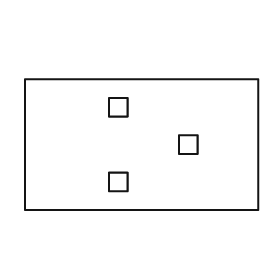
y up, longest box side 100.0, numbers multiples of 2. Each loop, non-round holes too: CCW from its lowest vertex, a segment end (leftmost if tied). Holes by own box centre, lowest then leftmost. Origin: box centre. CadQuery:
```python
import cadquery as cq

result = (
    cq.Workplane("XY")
    .moveTo(-50.0, -28.0)
    .lineTo(50.0, -28.0)
    .lineTo(50.0, 28.0)
    .lineTo(-50.0, 28.0)
    .close()
    .moveTo(-14.0, -20.0)
    .lineTo(-6.0, -20.0)
    .lineTo(-6.0, -12.0)
    .lineTo(-14.0, -12.0)
    .close()
    .moveTo(16.0, -4.0)
    .lineTo(24.0, -4.0)
    .lineTo(24.0, 4.0)
    .lineTo(16.0, 4.0)
    .close()
    .moveTo(-14.0, 12.0)
    .lineTo(-6.0, 12.0)
    .lineTo(-6.0, 20.0)
    .lineTo(-14.0, 20.0)
    .close()
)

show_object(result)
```